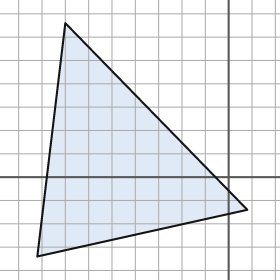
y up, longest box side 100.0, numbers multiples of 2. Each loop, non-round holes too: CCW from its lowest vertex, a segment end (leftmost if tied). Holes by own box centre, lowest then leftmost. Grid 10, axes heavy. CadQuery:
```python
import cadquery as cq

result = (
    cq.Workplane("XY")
    .moveTo(-82.0, -34.0)
    .lineTo(8.0, -14.0)
    .lineTo(-70.0, 66.0)
    .close()
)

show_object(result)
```